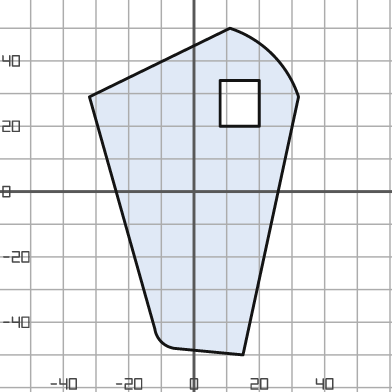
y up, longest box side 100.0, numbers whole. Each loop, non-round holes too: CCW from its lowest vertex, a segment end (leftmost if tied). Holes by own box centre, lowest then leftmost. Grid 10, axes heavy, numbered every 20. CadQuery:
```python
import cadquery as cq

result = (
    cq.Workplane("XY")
    .moveTo(15.0, -50.0)
    .lineTo(32.0, 29.0)
    .threePointArc((24.0, 42.0), (11.0, 50.0))
    .lineTo(-32.0, 29.0)
    .lineTo(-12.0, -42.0)
    .threePointArc((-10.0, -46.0), (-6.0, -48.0))
    .close()
    .moveTo(8.0, 20.0)
    .lineTo(20.0, 20.0)
    .lineTo(20.0, 34.0)
    .lineTo(8.0, 34.0)
    .close()
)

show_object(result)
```